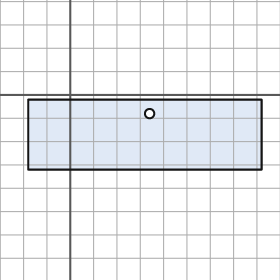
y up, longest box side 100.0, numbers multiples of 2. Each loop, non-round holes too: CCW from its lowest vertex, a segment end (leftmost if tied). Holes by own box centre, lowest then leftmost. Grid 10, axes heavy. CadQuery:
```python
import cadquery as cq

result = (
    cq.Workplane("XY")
    .moveTo(-18.0, -32.0)
    .lineTo(82.0, -32.0)
    .lineTo(82.0, -2.0)
    .lineTo(-18.0, -2.0)
    .close()
    .moveTo(34.0, -8.0)
    .circle(2.0)
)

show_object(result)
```